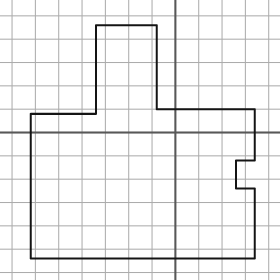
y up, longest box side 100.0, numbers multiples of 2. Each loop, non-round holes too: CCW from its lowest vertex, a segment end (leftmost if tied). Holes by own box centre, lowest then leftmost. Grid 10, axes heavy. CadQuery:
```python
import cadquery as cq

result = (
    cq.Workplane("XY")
    .moveTo(-62.0, -54.0)
    .lineTo(34.0, -54.0)
    .lineTo(34.0, -24.0)
    .lineTo(26.0, -24.0)
    .lineTo(26.0, -12.0)
    .lineTo(34.0, -12.0)
    .lineTo(34.0, 10.0)
    .lineTo(-8.0, 10.0)
    .lineTo(-8.0, 46.0)
    .lineTo(-34.0, 46.0)
    .lineTo(-34.0, 8.0)
    .lineTo(-62.0, 8.0)
    .close()
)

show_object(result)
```